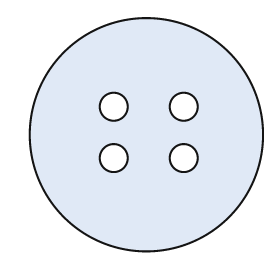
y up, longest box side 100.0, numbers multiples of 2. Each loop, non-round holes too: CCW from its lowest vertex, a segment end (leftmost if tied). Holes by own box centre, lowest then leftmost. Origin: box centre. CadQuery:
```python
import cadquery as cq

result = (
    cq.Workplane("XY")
    .moveTo(0.0, 0.0)
    .circle(50.0)
    .moveTo(-14.0, -10.0)
    .circle(6.0)
    .moveTo(16.0, -10.0)
    .circle(6.0)
    .moveTo(-14.0, 12.0)
    .circle(6.0)
    .moveTo(16.0, 12.0)
    .circle(6.0)
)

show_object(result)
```